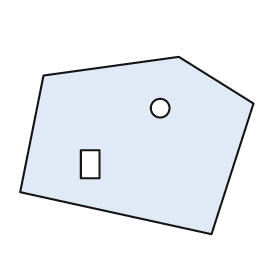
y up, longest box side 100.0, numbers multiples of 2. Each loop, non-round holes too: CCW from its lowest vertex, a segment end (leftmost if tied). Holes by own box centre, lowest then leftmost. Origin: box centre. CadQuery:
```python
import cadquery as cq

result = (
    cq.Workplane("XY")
    .moveTo(32.0, -38.0)
    .lineTo(50.0, 18.0)
    .lineTo(18.0, 38.0)
    .lineTo(-40.0, 30.0)
    .lineTo(-50.0, -20.0)
    .close()
    .moveTo(-24.0, -14.0)
    .lineTo(-16.0, -14.0)
    .lineTo(-16.0, -2.0)
    .lineTo(-24.0, -2.0)
    .close()
    .moveTo(10.0, 16.0)
    .circle(4.0)
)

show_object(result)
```